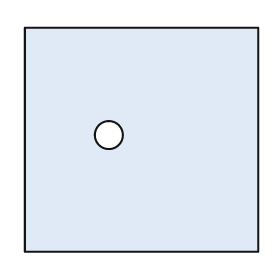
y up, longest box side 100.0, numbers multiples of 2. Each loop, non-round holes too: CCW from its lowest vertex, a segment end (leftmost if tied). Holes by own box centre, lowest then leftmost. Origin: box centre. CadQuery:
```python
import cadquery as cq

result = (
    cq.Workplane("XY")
    .moveTo(-50.0, -48.0)
    .lineTo(50.0, -48.0)
    .lineTo(50.0, 48.0)
    .lineTo(-50.0, 48.0)
    .close()
    .moveTo(-14.0, 2.0)
    .circle(6.0)
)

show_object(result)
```